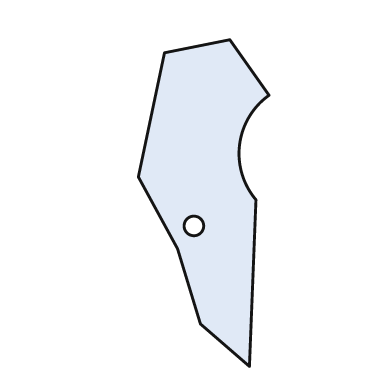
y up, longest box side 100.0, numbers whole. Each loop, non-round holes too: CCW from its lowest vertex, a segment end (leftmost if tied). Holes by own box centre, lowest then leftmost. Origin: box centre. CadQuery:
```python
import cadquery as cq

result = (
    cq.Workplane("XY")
    .moveTo(14.0, -50.0)
    .lineTo(16.0, 1.0)
    .threePointArc((11.0, 18.0), (20.0, 33.0))
    .lineTo(8.0, 50.0)
    .lineTo(-12.0, 46.0)
    .lineTo(-20.0, 8.0)
    .lineTo(-8.0, -14.0)
    .lineTo(-1.0, -37.0)
    .close()
    .moveTo(-3.0, -7.0)
    .circle(3.0)
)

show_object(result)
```